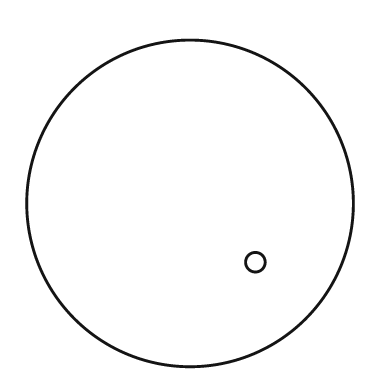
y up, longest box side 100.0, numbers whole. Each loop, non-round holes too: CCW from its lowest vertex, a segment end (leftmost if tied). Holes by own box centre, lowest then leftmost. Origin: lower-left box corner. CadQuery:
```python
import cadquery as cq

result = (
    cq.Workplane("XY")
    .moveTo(50.0, 50.0)
    .circle(50.0)
    .moveTo(70.0, 32.0)
    .circle(3.0)
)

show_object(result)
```